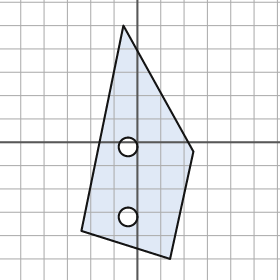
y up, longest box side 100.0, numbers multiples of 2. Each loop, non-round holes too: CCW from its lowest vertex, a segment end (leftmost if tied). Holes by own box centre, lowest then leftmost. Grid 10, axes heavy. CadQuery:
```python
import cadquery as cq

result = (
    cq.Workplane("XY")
    .moveTo(14.0, -50.0)
    .lineTo(24.0, -4.0)
    .lineTo(-6.0, 50.0)
    .lineTo(-24.0, -38.0)
    .close()
    .moveTo(-4.0, -32.0)
    .circle(4.0)
    .moveTo(-4.0, -2.0)
    .circle(4.0)
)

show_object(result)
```